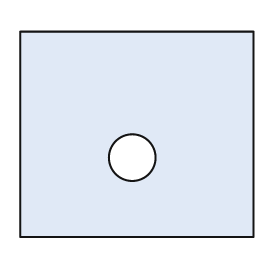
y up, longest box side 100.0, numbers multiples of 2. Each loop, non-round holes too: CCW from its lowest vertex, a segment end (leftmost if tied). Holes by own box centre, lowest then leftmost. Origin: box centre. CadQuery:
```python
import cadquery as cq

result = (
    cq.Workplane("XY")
    .moveTo(-50.0, -44.0)
    .lineTo(50.0, -44.0)
    .lineTo(50.0, 44.0)
    .lineTo(-50.0, 44.0)
    .close()
    .moveTo(-2.0, -10.0)
    .circle(10.0)
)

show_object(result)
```